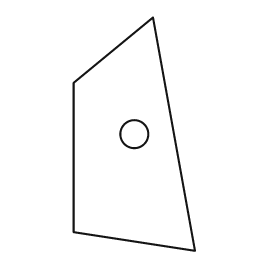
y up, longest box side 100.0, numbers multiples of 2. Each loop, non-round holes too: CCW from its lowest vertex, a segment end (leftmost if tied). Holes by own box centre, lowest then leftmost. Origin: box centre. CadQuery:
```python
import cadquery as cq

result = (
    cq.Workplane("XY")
    .moveTo(26.0, -50.0)
    .lineTo(8.0, 50.0)
    .lineTo(-26.0, 22.0)
    .lineTo(-26.0, -42.0)
    .close()
    .moveTo(0.0, 0.0)
    .circle(6.0)
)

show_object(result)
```